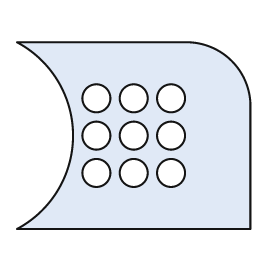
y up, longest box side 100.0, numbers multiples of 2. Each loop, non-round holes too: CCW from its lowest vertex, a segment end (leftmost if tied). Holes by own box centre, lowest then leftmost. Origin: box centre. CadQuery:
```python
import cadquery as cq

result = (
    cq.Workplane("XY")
    .moveTo(-50.0, -40.0)
    .lineTo(50.0, -40.0)
    .lineTo(50.0, 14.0)
    .threePointArc((42.0, 32.0), (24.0, 40.0))
    .lineTo(-50.0, 40.0)
    .threePointArc((-26.0, 0.0), (-50.0, -40.0))
    .close()
    .moveTo(-16.0, -16.0)
    .circle(6.0)
    .moveTo(0.0, -16.0)
    .circle(6.0)
    .moveTo(16.0, -16.0)
    .circle(6.0)
    .moveTo(-16.0, 0.0)
    .circle(6.0)
    .moveTo(0.0, 0.0)
    .circle(6.0)
    .moveTo(16.0, 0.0)
    .circle(6.0)
    .moveTo(-16.0, 16.0)
    .circle(6.0)
    .moveTo(0.0, 16.0)
    .circle(6.0)
    .moveTo(16.0, 16.0)
    .circle(6.0)
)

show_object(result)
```